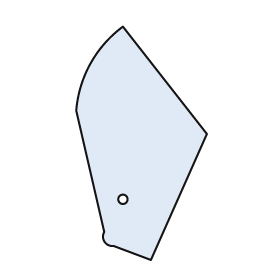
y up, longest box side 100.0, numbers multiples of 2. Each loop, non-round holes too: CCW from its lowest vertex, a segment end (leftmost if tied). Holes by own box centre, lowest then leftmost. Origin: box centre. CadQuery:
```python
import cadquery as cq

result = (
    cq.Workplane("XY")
    .moveTo(4.0, -50.0)
    .lineTo(28.0, 4.0)
    .lineTo(-8.0, 50.0)
    .threePointArc((-22.0, 34.0), (-28.0, 14.0))
    .lineTo(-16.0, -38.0)
    .threePointArc((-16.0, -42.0), (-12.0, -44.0))
    .close()
    .moveTo(-8.0, -24.0)
    .circle(2.0)
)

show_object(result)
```